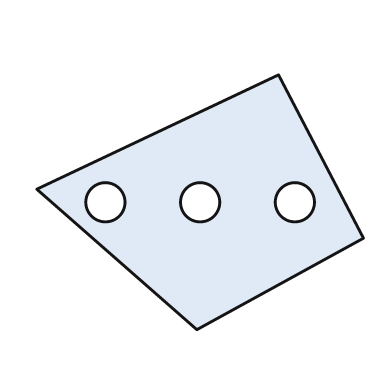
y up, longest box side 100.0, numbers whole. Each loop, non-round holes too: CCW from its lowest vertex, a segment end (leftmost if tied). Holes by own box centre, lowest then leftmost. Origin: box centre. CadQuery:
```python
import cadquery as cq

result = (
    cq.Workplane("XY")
    .moveTo(-1.0, -39.0)
    .lineTo(50.0, -11.0)
    .lineTo(24.0, 39.0)
    .lineTo(-50.0, 4.0)
    .close()
    .moveTo(-29.0, 0.0)
    .circle(6.0)
    .moveTo(0.0, 0.0)
    .circle(6.0)
    .moveTo(29.0, 0.0)
    .circle(6.0)
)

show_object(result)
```